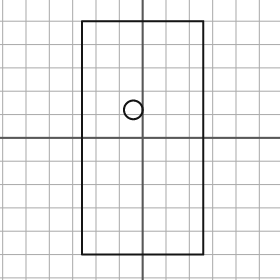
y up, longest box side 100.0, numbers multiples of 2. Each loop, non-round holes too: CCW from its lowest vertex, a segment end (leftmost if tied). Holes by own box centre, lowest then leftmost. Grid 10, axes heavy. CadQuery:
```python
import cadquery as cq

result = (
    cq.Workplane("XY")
    .moveTo(-26.0, -50.0)
    .lineTo(26.0, -50.0)
    .lineTo(26.0, 50.0)
    .lineTo(-26.0, 50.0)
    .close()
    .moveTo(-4.0, 12.0)
    .circle(4.0)
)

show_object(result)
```